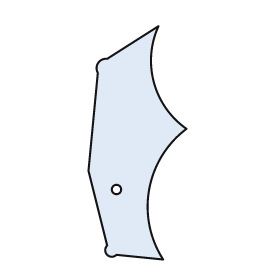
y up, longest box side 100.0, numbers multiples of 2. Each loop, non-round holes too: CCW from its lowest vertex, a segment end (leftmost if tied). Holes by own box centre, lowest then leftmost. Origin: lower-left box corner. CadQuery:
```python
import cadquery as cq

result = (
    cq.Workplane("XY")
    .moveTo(32.0, 0.0)
    .threePointArc((26.0, 30.0), (42.0, 56.0))
    .threePointArc((28.0, 76.0), (30.0, 100.0))
    .lineTo(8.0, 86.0)
    .threePointArc((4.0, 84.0), (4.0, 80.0))
    .lineTo(0.0, 38.0)
    .lineTo(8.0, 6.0)
    .threePointArc((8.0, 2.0), (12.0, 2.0))
    .close()
    .moveTo(12.0, 30.0)
    .circle(2.0)
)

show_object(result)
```